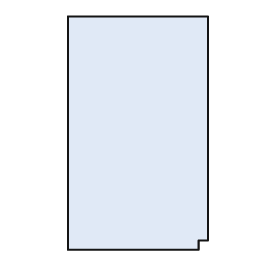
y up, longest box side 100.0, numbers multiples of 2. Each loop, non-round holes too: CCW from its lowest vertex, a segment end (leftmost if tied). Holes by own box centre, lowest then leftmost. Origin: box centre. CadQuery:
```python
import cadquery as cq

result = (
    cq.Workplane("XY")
    .moveTo(-30.0, -50.0)
    .lineTo(26.0, -50.0)
    .lineTo(26.0, -46.0)
    .lineTo(30.0, -46.0)
    .lineTo(30.0, 50.0)
    .lineTo(-30.0, 50.0)
    .close()
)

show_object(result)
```